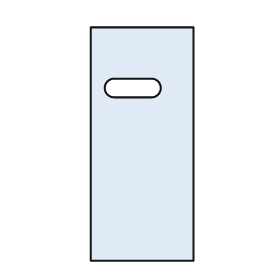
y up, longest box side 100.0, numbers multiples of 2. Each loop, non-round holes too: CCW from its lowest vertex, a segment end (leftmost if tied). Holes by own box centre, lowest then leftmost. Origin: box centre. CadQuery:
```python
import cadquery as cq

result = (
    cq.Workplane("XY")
    .moveTo(-22.0, -50.0)
    .lineTo(22.0, -50.0)
    .lineTo(22.0, 50.0)
    .lineTo(-22.0, 50.0)
    .close()
    .moveTo(-12.0, 20.0)
    .lineTo(4.0, 20.0)
    .threePointArc((8.0, 24.0), (4.0, 28.0))
    .lineTo(-12.0, 28.0)
    .threePointArc((-16.0, 24.0), (-12.0, 20.0))
    .close()
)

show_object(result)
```